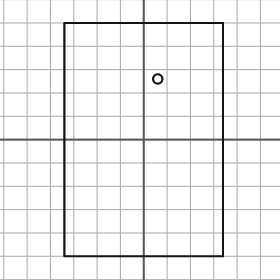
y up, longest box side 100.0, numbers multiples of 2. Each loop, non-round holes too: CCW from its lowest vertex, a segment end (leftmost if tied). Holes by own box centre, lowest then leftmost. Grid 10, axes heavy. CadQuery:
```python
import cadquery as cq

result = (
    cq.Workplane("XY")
    .moveTo(-34.0, -50.0)
    .lineTo(34.0, -50.0)
    .lineTo(34.0, 50.0)
    .lineTo(-34.0, 50.0)
    .close()
    .moveTo(6.0, 26.0)
    .circle(2.0)
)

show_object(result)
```